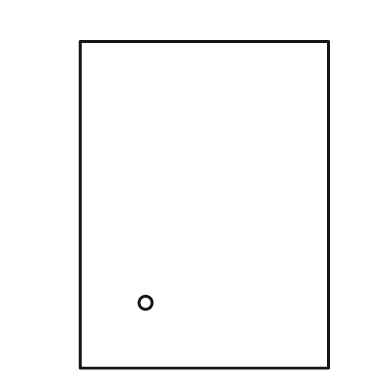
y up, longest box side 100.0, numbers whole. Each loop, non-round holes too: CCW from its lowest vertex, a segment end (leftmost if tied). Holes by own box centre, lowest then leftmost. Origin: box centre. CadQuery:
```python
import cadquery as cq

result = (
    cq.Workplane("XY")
    .moveTo(-38.0, -50.0)
    .lineTo(38.0, -50.0)
    .lineTo(38.0, 50.0)
    .lineTo(-38.0, 50.0)
    .close()
    .moveTo(-18.0, -30.0)
    .circle(2.0)
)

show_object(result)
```